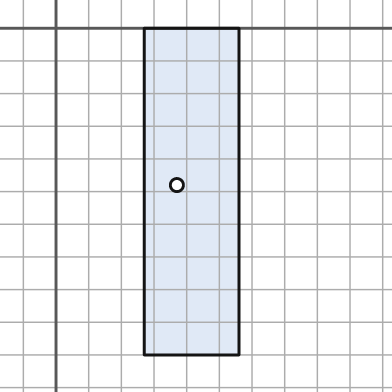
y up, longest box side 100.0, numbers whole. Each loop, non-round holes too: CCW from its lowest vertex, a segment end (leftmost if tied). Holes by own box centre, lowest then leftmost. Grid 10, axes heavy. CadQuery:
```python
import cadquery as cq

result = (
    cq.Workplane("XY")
    .moveTo(27.0, -100.0)
    .lineTo(56.0, -100.0)
    .lineTo(56.0, 0.0)
    .lineTo(27.0, 0.0)
    .close()
    .moveTo(37.0, -48.0)
    .circle(2.0)
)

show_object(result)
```